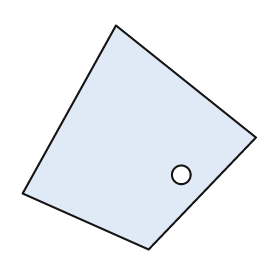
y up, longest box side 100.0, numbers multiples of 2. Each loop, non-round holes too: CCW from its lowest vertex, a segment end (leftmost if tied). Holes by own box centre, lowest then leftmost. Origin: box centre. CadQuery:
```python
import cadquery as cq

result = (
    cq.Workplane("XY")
    .moveTo(4.0, -48.0)
    .lineTo(50.0, 0.0)
    .lineTo(-10.0, 48.0)
    .lineTo(-50.0, -24.0)
    .close()
    .moveTo(18.0, -16.0)
    .circle(4.0)
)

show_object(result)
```